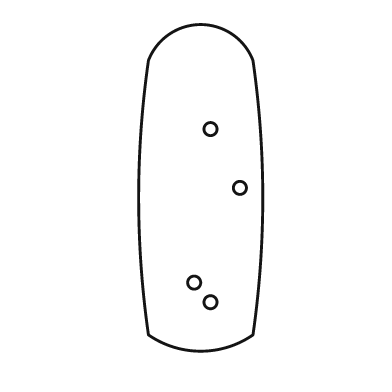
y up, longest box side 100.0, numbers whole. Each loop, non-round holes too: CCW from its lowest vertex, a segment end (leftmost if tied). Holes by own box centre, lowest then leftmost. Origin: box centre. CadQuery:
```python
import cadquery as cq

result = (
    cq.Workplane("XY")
    .moveTo(-16.0, -45.0)
    .threePointArc((0.0, -50.0), (16.0, -45.0))
    .threePointArc((19.0, -3.0), (16.0, 39.0))
    .threePointArc((0.0, 50.0), (-16.0, 39.0))
    .threePointArc((-19.0, -3.0), (-16.0, -45.0))
    .close()
    .moveTo(3.0, -35.0)
    .circle(2.0)
    .moveTo(-2.0, -29.0)
    .circle(2.0)
    .moveTo(12.0, 0.0)
    .circle(2.0)
    .moveTo(3.0, 18.0)
    .circle(2.0)
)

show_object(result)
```